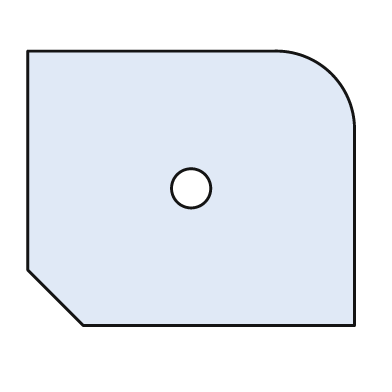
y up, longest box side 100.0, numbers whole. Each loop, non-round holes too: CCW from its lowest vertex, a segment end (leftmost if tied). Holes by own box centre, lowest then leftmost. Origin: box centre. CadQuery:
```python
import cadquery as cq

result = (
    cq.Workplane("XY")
    .moveTo(-33.0, -42.0)
    .lineTo(50.0, -42.0)
    .lineTo(50.0, 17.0)
    .threePointArc((43.0, 35.0), (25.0, 42.0))
    .lineTo(-50.0, 42.0)
    .lineTo(-50.0, -25.0)
    .close()
    .moveTo(0.0, 0.0)
    .circle(6.0)
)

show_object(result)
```